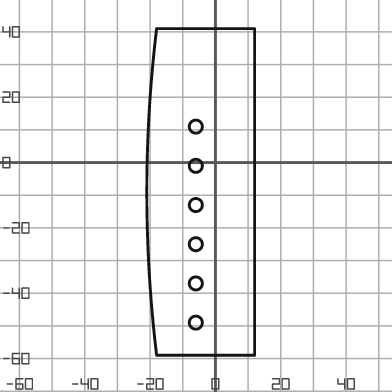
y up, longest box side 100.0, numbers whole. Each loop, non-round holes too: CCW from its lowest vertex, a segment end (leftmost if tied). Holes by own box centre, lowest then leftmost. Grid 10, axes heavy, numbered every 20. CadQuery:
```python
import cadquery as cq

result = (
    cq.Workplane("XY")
    .moveTo(-18.0, -59.0)
    .lineTo(12.0, -59.0)
    .lineTo(12.0, 41.0)
    .lineTo(-18.0, 41.0)
    .threePointArc((-21.0, -9.0), (-18.0, -59.0))
    .close()
    .moveTo(-6.0, -49.0)
    .circle(2.0)
    .moveTo(-6.0, -37.0)
    .circle(2.0)
    .moveTo(-6.0, -25.0)
    .circle(2.0)
    .moveTo(-6.0, -13.0)
    .circle(2.0)
    .moveTo(-6.0, -1.0)
    .circle(2.0)
    .moveTo(-6.0, 11.0)
    .circle(2.0)
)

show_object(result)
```